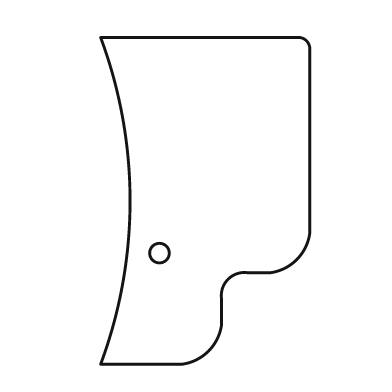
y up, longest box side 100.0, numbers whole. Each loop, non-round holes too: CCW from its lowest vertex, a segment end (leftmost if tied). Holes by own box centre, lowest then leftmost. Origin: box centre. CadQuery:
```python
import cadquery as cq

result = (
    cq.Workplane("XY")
    .moveTo(-32.0, -50.0)
    .lineTo(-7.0, -50.0)
    .threePointArc((1.0, -46.0), (5.0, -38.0))
    .lineTo(5.0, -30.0)
    .threePointArc((7.0, -24.0), (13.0, -22.0))
    .lineTo(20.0, -22.0)
    .threePointArc((28.0, -18.0), (32.0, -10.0))
    .lineTo(32.0, 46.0)
    .threePointArc((31.0, 49.0), (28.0, 50.0))
    .lineTo(-32.0, 50.0)
    .threePointArc((-23.0, 0.0), (-32.0, -50.0))
    .close()
    .moveTo(-14.0, -16.0)
    .circle(3.0)
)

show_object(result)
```